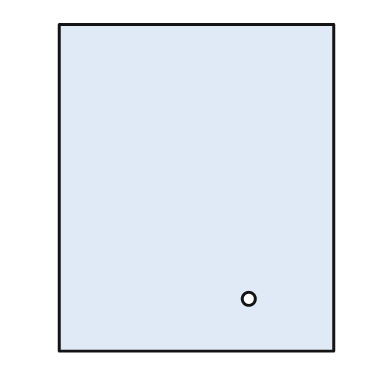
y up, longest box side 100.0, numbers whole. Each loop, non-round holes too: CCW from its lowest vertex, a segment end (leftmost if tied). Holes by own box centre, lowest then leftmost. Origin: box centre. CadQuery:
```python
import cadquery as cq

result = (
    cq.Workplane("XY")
    .moveTo(-42.0, -50.0)
    .lineTo(42.0, -50.0)
    .lineTo(42.0, 50.0)
    .lineTo(-42.0, 50.0)
    .close()
    .moveTo(16.0, -34.0)
    .circle(2.0)
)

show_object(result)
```